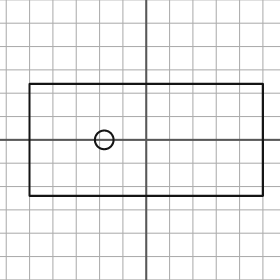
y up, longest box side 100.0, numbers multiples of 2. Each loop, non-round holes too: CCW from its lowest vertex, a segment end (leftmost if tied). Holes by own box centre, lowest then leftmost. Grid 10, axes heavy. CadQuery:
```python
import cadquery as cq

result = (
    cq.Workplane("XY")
    .moveTo(-50.0, -24.0)
    .lineTo(50.0, -24.0)
    .lineTo(50.0, 24.0)
    .lineTo(-50.0, 24.0)
    .close()
    .moveTo(-18.0, 0.0)
    .circle(4.0)
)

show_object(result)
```